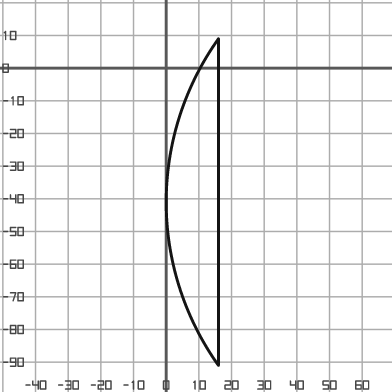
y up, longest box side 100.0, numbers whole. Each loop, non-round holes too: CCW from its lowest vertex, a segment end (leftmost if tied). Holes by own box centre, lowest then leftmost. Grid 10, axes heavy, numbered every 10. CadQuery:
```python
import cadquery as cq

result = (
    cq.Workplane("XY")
    .moveTo(16.0, -91.0)
    .lineTo(16.0, 9.0)
    .threePointArc((0.0, -41.0), (16.0, -91.0))
    .close()
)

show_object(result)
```